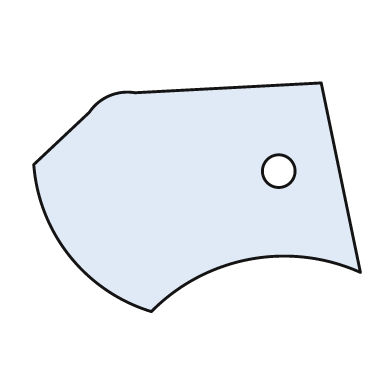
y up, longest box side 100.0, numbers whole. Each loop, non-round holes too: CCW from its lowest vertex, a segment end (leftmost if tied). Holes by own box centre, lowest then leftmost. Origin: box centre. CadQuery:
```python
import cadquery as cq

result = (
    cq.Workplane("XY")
    .moveTo(-14.0, -35.0)
    .threePointArc((16.0, -19.0), (50.0, -23.0))
    .lineTo(38.0, 35.0)
    .lineTo(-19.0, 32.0)
    .threePointArc((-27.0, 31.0), (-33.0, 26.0))
    .lineTo(-50.0, 10.0)
    .threePointArc((-39.0, -18.0), (-14.0, -35.0))
    .close()
    .moveTo(25.0, 8.0)
    .circle(5.0)
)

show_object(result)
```